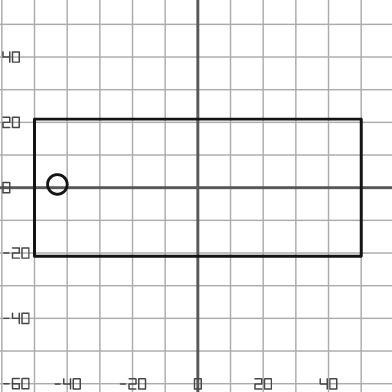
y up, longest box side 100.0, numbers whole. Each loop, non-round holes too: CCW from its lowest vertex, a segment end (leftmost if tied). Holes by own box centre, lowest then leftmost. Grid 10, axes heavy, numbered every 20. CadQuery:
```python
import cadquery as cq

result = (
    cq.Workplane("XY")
    .moveTo(-50.0, -21.0)
    .lineTo(50.0, -21.0)
    .lineTo(50.0, 21.0)
    .lineTo(-50.0, 21.0)
    .close()
    .moveTo(-43.0, 1.0)
    .circle(3.0)
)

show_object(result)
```